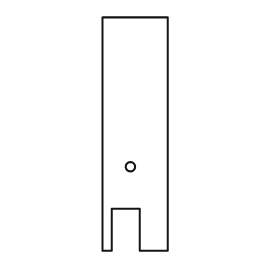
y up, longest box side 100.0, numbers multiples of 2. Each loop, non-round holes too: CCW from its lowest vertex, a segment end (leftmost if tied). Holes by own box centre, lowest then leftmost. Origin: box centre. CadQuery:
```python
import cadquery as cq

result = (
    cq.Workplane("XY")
    .moveTo(-14.0, -50.0)
    .lineTo(-10.0, -50.0)
    .lineTo(-10.0, -32.0)
    .lineTo(2.0, -32.0)
    .lineTo(2.0, -50.0)
    .lineTo(14.0, -50.0)
    .lineTo(14.0, 50.0)
    .lineTo(-14.0, 50.0)
    .close()
    .moveTo(-2.0, -14.0)
    .circle(2.0)
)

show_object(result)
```